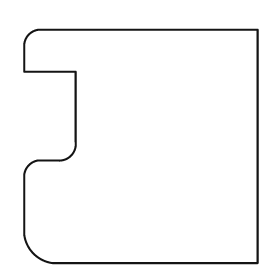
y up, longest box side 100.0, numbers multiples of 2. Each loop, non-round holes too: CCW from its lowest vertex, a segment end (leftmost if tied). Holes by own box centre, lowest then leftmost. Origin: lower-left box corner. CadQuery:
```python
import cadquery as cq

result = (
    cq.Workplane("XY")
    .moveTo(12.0, 0.0)
    .lineTo(100.0, 0.0)
    .lineTo(100.0, 100.0)
    .lineTo(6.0, 100.0)
    .threePointArc((2.0, 98.0), (0.0, 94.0))
    .lineTo(0.0, 82.0)
    .lineTo(22.0, 82.0)
    .lineTo(22.0, 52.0)
    .threePointArc((20.0, 46.0), (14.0, 44.0))
    .lineTo(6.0, 44.0)
    .threePointArc((2.0, 42.0), (0.0, 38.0))
    .lineTo(0.0, 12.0)
    .threePointArc((4.0, 4.0), (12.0, 0.0))
    .close()
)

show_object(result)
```